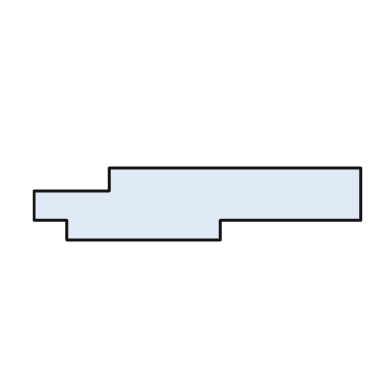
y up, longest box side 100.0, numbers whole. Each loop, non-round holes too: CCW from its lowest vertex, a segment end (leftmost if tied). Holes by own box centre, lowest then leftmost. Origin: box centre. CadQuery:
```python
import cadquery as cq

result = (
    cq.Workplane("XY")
    .moveTo(-40.0, -11.0)
    .lineTo(7.0, -11.0)
    .lineTo(7.0, -5.0)
    .lineTo(50.0, -5.0)
    .lineTo(50.0, 11.0)
    .lineTo(-27.0, 11.0)
    .lineTo(-27.0, 4.0)
    .lineTo(-50.0, 4.0)
    .lineTo(-50.0, -5.0)
    .lineTo(-40.0, -5.0)
    .close()
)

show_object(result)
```